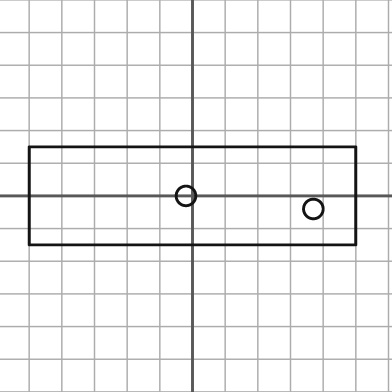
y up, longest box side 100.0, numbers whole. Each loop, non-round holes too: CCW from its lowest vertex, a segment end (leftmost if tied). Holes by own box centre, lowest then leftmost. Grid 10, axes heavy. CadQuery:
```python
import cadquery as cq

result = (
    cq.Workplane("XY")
    .moveTo(-50.0, -15.0)
    .lineTo(50.0, -15.0)
    .lineTo(50.0, 15.0)
    .lineTo(-50.0, 15.0)
    .close()
    .moveTo(37.0, -4.0)
    .circle(3.0)
    .moveTo(-2.0, 0.0)
    .circle(3.0)
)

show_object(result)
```